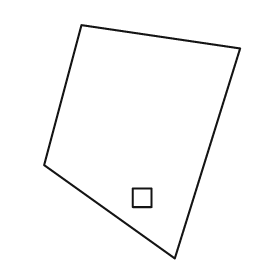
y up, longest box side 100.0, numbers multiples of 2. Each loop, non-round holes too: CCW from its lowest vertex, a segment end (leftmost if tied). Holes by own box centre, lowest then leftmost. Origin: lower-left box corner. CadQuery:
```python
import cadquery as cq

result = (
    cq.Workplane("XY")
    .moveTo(56.0, 0.0)
    .lineTo(84.0, 90.0)
    .lineTo(16.0, 100.0)
    .lineTo(0.0, 40.0)
    .close()
    .moveTo(38.0, 22.0)
    .lineTo(46.0, 22.0)
    .lineTo(46.0, 30.0)
    .lineTo(38.0, 30.0)
    .close()
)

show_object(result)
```